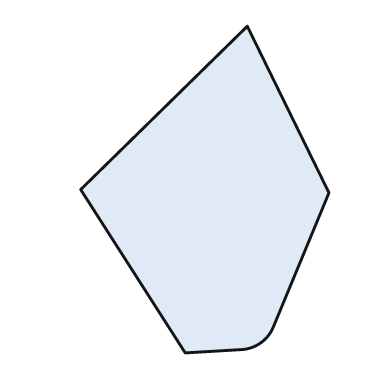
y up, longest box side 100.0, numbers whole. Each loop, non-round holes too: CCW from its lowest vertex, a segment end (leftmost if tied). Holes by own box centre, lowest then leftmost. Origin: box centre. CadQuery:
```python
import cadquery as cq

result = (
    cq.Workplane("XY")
    .moveTo(-6.0, -50.0)
    .lineTo(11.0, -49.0)
    .threePointArc((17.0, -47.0), (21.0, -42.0))
    .lineTo(38.0, -1.0)
    .lineTo(13.0, 50.0)
    .lineTo(-38.0, 0.0)
    .close()
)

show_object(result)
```